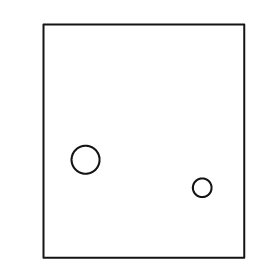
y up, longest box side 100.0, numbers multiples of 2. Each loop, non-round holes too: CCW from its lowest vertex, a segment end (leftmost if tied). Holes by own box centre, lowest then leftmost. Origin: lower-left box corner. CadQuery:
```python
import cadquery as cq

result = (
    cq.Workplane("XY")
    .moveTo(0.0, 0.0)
    .lineTo(86.0, 0.0)
    .lineTo(86.0, 100.0)
    .lineTo(0.0, 100.0)
    .close()
    .moveTo(68.0, 30.0)
    .circle(4.0)
    .moveTo(18.0, 42.0)
    .circle(6.0)
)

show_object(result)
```